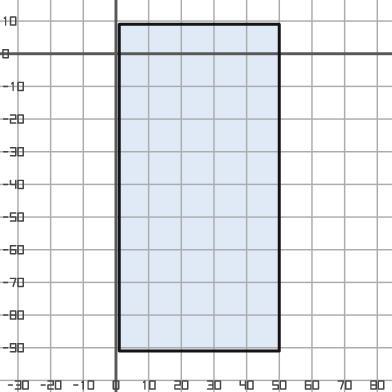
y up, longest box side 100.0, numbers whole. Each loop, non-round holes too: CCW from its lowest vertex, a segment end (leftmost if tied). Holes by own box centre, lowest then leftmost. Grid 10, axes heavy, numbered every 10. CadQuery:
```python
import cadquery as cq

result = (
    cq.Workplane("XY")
    .moveTo(1.0, -91.0)
    .lineTo(50.0, -91.0)
    .lineTo(50.0, 9.0)
    .lineTo(1.0, 9.0)
    .close()
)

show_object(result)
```